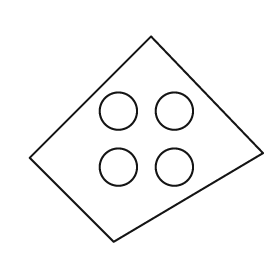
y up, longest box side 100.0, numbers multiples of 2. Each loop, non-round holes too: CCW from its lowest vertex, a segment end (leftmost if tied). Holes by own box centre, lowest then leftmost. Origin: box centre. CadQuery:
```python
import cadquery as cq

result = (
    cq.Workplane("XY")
    .moveTo(-14.0, -44.0)
    .lineTo(50.0, -6.0)
    .lineTo(2.0, 44.0)
    .lineTo(-50.0, -8.0)
    .close()
    .moveTo(-12.0, -12.0)
    .circle(8.0)
    .moveTo(12.0, -12.0)
    .circle(8.0)
    .moveTo(-12.0, 12.0)
    .circle(8.0)
    .moveTo(12.0, 12.0)
    .circle(8.0)
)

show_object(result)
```